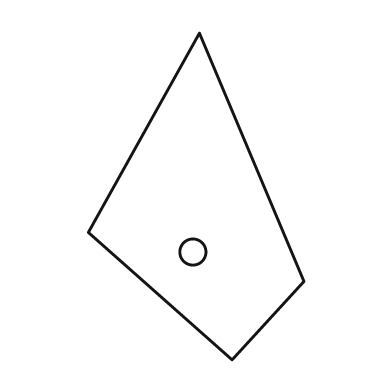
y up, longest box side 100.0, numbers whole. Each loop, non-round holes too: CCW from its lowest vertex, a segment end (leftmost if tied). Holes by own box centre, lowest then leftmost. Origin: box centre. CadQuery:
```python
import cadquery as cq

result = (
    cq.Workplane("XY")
    .moveTo(11.0, -50.0)
    .lineTo(33.0, -26.0)
    .lineTo(1.0, 50.0)
    .lineTo(-33.0, -11.0)
    .close()
    .moveTo(-1.0, -17.0)
    .circle(4.0)
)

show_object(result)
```